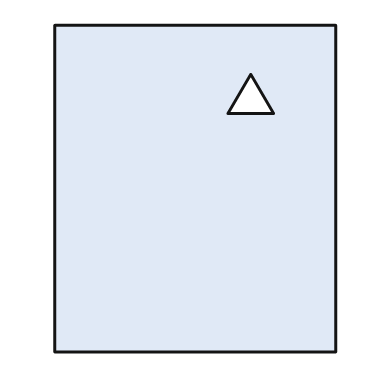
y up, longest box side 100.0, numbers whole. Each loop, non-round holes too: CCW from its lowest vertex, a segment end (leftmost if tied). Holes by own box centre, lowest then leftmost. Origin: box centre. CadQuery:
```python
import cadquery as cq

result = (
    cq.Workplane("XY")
    .moveTo(-43.0, -50.0)
    .lineTo(43.0, -50.0)
    .lineTo(43.0, 50.0)
    .lineTo(-43.0, 50.0)
    .close()
    .moveTo(10.0, 23.0)
    .lineTo(24.0, 23.0)
    .lineTo(17.0, 35.0)
    .close()
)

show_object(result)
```